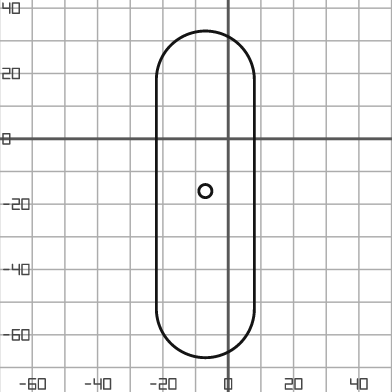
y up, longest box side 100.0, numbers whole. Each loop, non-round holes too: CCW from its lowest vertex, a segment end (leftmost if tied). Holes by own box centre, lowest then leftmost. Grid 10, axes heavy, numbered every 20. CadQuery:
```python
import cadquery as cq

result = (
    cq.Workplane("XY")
    .moveTo(-22.0, -52.0)
    .threePointArc((-7.0, -67.0), (8.0, -52.0))
    .lineTo(8.0, 18.0)
    .threePointArc((-7.0, 33.0), (-22.0, 18.0))
    .close()
    .moveTo(-7.0, -16.0)
    .circle(2.0)
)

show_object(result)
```